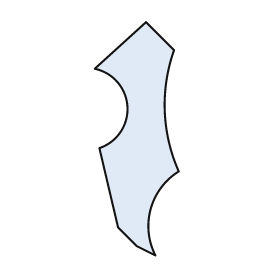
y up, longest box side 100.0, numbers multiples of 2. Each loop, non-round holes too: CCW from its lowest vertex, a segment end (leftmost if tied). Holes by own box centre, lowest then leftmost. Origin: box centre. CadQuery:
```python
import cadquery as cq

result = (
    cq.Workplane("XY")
    .moveTo(8.0, -50.0)
    .threePointArc((6.0, -30.0), (18.0, -14.0))
    .threePointArc((12.0, 12.0), (16.0, 38.0))
    .lineTo(4.0, 50.0)
    .lineTo(-18.0, 30.0)
    .threePointArc((-4.0, 14.0), (-16.0, -4.0))
    .lineTo(-8.0, -38.0)
    .lineTo(0.0, -46.0)
    .close()
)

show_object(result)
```